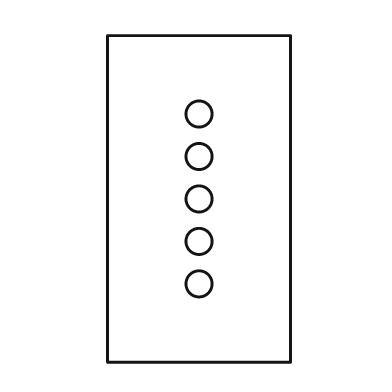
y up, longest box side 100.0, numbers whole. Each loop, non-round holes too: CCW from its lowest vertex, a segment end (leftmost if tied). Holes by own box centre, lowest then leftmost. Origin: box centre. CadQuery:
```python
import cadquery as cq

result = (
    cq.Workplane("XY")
    .moveTo(-28.0, -50.0)
    .lineTo(28.0, -50.0)
    .lineTo(28.0, 50.0)
    .lineTo(-28.0, 50.0)
    .close()
    .moveTo(0.0, -26.0)
    .circle(4.0)
    .moveTo(0.0, -13.0)
    .circle(4.0)
    .moveTo(0.0, 0.0)
    .circle(4.0)
    .moveTo(0.0, 13.0)
    .circle(4.0)
    .moveTo(0.0, 26.0)
    .circle(4.0)
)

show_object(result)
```